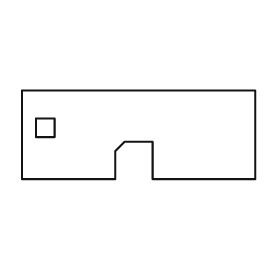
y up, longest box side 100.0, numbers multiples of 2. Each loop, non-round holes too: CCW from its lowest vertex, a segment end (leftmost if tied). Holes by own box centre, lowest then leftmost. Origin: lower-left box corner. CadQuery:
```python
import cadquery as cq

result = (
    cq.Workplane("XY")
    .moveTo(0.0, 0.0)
    .lineTo(40.0, 0.0)
    .lineTo(40.0, 12.0)
    .lineTo(44.0, 16.0)
    .lineTo(56.0, 16.0)
    .lineTo(56.0, 0.0)
    .lineTo(100.0, 0.0)
    .lineTo(100.0, 38.0)
    .lineTo(0.0, 38.0)
    .close()
    .moveTo(6.0, 18.0)
    .lineTo(14.0, 18.0)
    .lineTo(14.0, 26.0)
    .lineTo(6.0, 26.0)
    .close()
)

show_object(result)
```